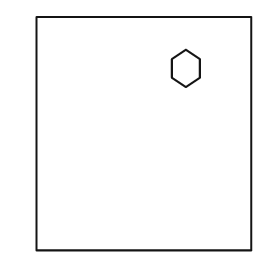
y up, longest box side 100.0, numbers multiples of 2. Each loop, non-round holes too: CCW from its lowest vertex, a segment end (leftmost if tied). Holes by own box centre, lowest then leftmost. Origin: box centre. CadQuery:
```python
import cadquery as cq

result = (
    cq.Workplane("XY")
    .moveTo(-46.0, -50.0)
    .lineTo(46.0, -50.0)
    .lineTo(46.0, 50.0)
    .lineTo(-46.0, 50.0)
    .close()
    .moveTo(18.0, 20.0)
    .lineTo(24.0, 24.0)
    .lineTo(24.0, 32.0)
    .lineTo(18.0, 36.0)
    .lineTo(12.0, 32.0)
    .lineTo(12.0, 24.0)
    .close()
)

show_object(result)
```